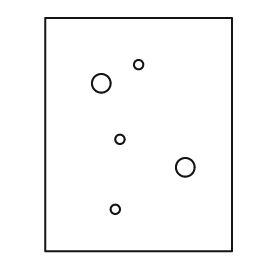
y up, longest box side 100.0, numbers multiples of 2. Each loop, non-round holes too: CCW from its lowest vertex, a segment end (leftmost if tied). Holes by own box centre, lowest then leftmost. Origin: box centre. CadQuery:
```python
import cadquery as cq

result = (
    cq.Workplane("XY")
    .moveTo(-40.0, -50.0)
    .lineTo(40.0, -50.0)
    .lineTo(40.0, 50.0)
    .lineTo(-40.0, 50.0)
    .close()
    .moveTo(-10.0, -32.0)
    .circle(2.0)
    .moveTo(20.0, -14.0)
    .circle(4.0)
    .moveTo(-8.0, -2.0)
    .circle(2.0)
    .moveTo(-16.0, 22.0)
    .circle(4.0)
    .moveTo(0.0, 30.0)
    .circle(2.0)
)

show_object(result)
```